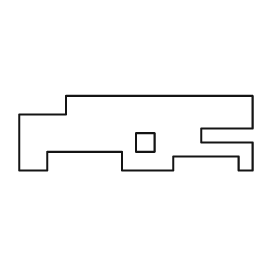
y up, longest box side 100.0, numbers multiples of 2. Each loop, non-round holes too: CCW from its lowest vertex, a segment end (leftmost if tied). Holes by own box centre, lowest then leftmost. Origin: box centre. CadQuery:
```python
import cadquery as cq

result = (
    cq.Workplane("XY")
    .moveTo(-50.0, -16.0)
    .lineTo(-38.0, -16.0)
    .lineTo(-38.0, -8.0)
    .lineTo(-6.0, -8.0)
    .lineTo(-6.0, -16.0)
    .lineTo(16.0, -16.0)
    .lineTo(16.0, -10.0)
    .lineTo(44.0, -10.0)
    .lineTo(44.0, -16.0)
    .lineTo(50.0, -16.0)
    .lineTo(50.0, -4.0)
    .lineTo(28.0, -4.0)
    .lineTo(28.0, 2.0)
    .lineTo(50.0, 2.0)
    .lineTo(50.0, 16.0)
    .lineTo(-30.0, 16.0)
    .lineTo(-30.0, 8.0)
    .lineTo(-50.0, 8.0)
    .close()
    .moveTo(0.0, -8.0)
    .lineTo(8.0, -8.0)
    .lineTo(8.0, 0.0)
    .lineTo(0.0, 0.0)
    .close()
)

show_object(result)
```